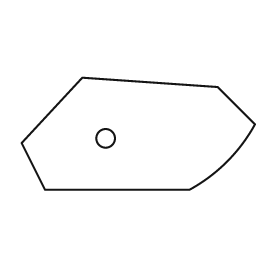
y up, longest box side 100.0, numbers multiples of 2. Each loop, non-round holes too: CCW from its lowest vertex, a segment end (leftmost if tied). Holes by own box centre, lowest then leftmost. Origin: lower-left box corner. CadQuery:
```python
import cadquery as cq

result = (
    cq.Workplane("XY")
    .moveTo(10.0, 0.0)
    .lineTo(72.0, 0.0)
    .threePointArc((88.0, 12.0), (100.0, 28.0))
    .lineTo(84.0, 44.0)
    .lineTo(26.0, 48.0)
    .lineTo(0.0, 20.0)
    .close()
    .moveTo(36.0, 22.0)
    .circle(4.0)
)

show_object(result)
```